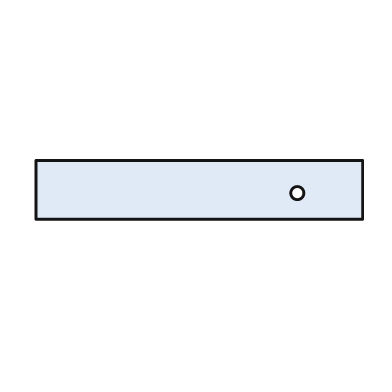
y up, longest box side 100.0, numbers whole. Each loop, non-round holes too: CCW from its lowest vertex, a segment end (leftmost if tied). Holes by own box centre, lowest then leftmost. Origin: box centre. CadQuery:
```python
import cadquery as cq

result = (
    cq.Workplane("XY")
    .moveTo(-50.0, -9.0)
    .lineTo(50.0, -9.0)
    .lineTo(50.0, 9.0)
    .lineTo(-50.0, 9.0)
    .close()
    .moveTo(30.0, -1.0)
    .circle(2.0)
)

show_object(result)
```